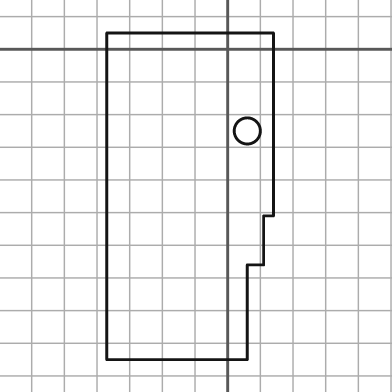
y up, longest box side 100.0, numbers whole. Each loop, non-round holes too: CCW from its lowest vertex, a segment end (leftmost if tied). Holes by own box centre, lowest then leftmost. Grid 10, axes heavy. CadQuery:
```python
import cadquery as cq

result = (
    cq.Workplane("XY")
    .moveTo(-37.0, -95.0)
    .lineTo(6.0, -95.0)
    .lineTo(6.0, -66.0)
    .lineTo(11.0, -66.0)
    .lineTo(11.0, -51.0)
    .lineTo(14.0, -51.0)
    .lineTo(14.0, 5.0)
    .lineTo(-37.0, 5.0)
    .close()
    .moveTo(6.0, -25.0)
    .circle(4.0)
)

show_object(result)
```